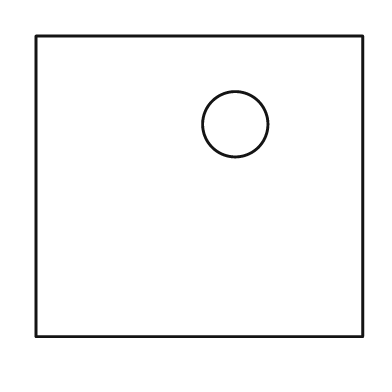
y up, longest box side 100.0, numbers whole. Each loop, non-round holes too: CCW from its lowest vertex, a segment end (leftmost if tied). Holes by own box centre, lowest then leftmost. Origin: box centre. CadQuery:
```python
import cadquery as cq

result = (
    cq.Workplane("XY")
    .moveTo(-50.0, -46.0)
    .lineTo(50.0, -46.0)
    .lineTo(50.0, 46.0)
    .lineTo(-50.0, 46.0)
    .close()
    .moveTo(11.0, 19.0)
    .circle(10.0)
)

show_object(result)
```